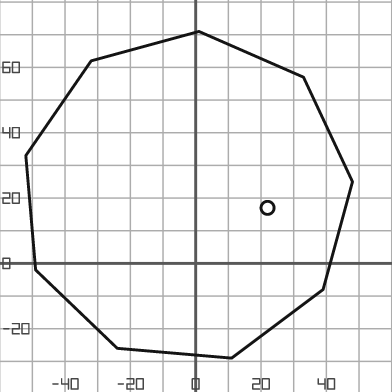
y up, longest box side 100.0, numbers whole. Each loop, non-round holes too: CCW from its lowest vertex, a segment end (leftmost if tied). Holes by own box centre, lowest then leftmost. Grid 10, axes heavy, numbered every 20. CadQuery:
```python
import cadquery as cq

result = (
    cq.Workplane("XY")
    .moveTo(11.0, -29.0)
    .lineTo(39.0, -8.0)
    .lineTo(48.0, 25.0)
    .lineTo(33.0, 57.0)
    .lineTo(1.0, 71.0)
    .lineTo(-32.0, 62.0)
    .lineTo(-52.0, 33.0)
    .lineTo(-49.0, -2.0)
    .lineTo(-24.0, -26.0)
    .close()
    .moveTo(22.0, 17.0)
    .circle(2.0)
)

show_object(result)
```